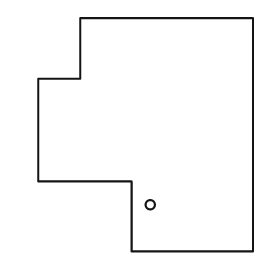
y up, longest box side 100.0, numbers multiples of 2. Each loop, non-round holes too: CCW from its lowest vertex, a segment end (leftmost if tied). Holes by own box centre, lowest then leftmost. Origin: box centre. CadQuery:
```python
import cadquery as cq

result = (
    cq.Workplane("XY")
    .moveTo(-6.0, -50.0)
    .lineTo(46.0, -50.0)
    .lineTo(46.0, 50.0)
    .lineTo(-28.0, 50.0)
    .lineTo(-28.0, 24.0)
    .lineTo(-46.0, 24.0)
    .lineTo(-46.0, -20.0)
    .lineTo(-6.0, -20.0)
    .close()
    .moveTo(2.0, -30.0)
    .circle(2.0)
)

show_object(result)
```